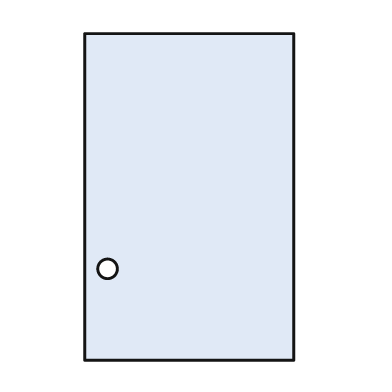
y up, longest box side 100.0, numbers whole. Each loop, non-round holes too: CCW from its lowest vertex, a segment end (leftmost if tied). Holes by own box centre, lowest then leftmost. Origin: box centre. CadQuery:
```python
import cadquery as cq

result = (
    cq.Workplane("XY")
    .moveTo(-32.0, -50.0)
    .lineTo(32.0, -50.0)
    .lineTo(32.0, 50.0)
    .lineTo(-32.0, 50.0)
    .close()
    .moveTo(-25.0, -22.0)
    .circle(3.0)
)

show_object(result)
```